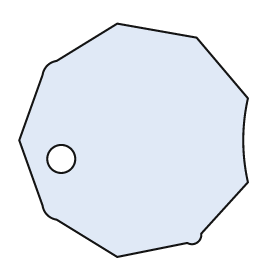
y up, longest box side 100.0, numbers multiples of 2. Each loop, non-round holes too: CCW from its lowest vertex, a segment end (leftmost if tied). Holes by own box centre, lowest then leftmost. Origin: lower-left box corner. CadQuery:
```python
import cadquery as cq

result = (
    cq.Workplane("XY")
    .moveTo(42.0, 0.0)
    .lineTo(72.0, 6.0)
    .threePointArc((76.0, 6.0), (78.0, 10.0))
    .lineTo(98.0, 32.0)
    .threePointArc((96.0, 50.0), (98.0, 68.0))
    .lineTo(76.0, 94.0)
    .lineTo(42.0, 100.0)
    .lineTo(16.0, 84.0)
    .threePointArc((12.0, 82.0), (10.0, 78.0))
    .lineTo(0.0, 50.0)
    .lineTo(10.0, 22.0)
    .threePointArc((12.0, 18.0), (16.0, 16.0))
    .close()
    .moveTo(18.0, 42.0)
    .circle(6.0)
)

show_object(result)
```